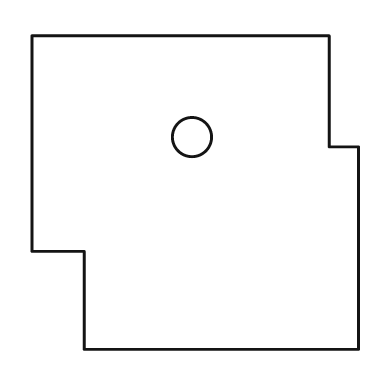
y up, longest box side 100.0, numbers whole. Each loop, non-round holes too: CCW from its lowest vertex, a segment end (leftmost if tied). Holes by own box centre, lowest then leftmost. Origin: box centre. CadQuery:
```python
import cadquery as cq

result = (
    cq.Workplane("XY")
    .moveTo(-34.0, -48.0)
    .lineTo(50.0, -48.0)
    .lineTo(50.0, 14.0)
    .lineTo(41.0, 14.0)
    .lineTo(41.0, 48.0)
    .lineTo(-50.0, 48.0)
    .lineTo(-50.0, -18.0)
    .lineTo(-34.0, -18.0)
    .close()
    .moveTo(-1.0, 17.0)
    .circle(6.0)
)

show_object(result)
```